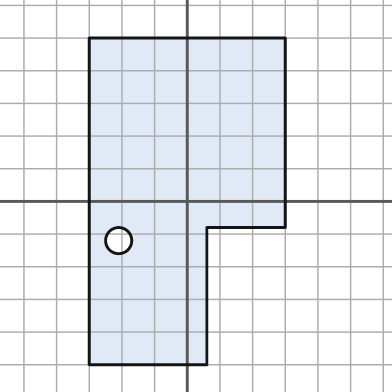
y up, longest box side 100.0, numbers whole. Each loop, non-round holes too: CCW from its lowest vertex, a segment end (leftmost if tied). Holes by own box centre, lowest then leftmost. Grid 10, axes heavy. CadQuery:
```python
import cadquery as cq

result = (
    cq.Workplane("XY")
    .moveTo(-30.0, -50.0)
    .lineTo(6.0, -50.0)
    .lineTo(6.0, -8.0)
    .lineTo(30.0, -8.0)
    .lineTo(30.0, 50.0)
    .lineTo(-30.0, 50.0)
    .close()
    .moveTo(-21.0, -12.0)
    .circle(4.0)
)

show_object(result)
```